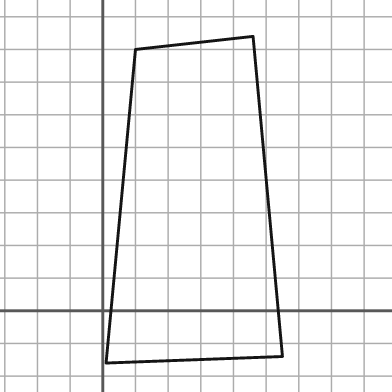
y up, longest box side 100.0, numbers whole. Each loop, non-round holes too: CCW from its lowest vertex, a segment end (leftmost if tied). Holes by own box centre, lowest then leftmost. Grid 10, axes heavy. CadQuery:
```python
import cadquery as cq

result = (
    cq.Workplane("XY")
    .moveTo(1.0, -16.0)
    .lineTo(55.0, -14.0)
    .lineTo(46.0, 84.0)
    .lineTo(10.0, 80.0)
    .close()
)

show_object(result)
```